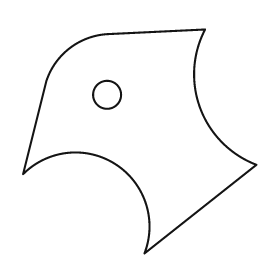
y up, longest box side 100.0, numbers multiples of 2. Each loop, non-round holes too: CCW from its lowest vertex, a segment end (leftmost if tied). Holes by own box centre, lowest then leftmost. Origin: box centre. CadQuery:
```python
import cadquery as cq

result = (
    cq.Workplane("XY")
    .moveTo(2.0, -48.0)
    .lineTo(50.0, -10.0)
    .threePointArc((26.0, 14.0), (28.0, 48.0))
    .lineTo(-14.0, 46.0)
    .threePointArc((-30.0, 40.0), (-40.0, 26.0))
    .lineTo(-50.0, -14.0)
    .threePointArc((-10.0, -10.0), (2.0, -48.0))
    .close()
    .moveTo(-14.0, 20.0)
    .circle(6.0)
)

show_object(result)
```